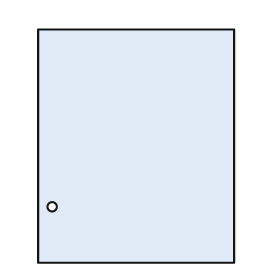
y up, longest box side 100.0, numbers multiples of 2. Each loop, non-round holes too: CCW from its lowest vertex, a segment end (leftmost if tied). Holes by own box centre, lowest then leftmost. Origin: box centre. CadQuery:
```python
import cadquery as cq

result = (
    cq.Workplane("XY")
    .moveTo(-42.0, -50.0)
    .lineTo(42.0, -50.0)
    .lineTo(42.0, 50.0)
    .lineTo(-42.0, 50.0)
    .close()
    .moveTo(-36.0, -26.0)
    .circle(2.0)
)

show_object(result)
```